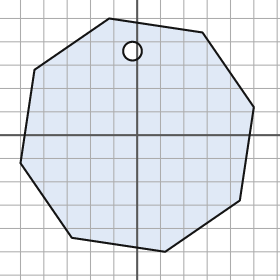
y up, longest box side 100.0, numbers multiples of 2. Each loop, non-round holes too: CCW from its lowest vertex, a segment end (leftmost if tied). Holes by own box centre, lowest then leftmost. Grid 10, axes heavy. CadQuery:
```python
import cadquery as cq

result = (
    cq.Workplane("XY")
    .moveTo(12.0, -50.0)
    .lineTo(44.0, -28.0)
    .lineTo(50.0, 12.0)
    .lineTo(28.0, 44.0)
    .lineTo(-12.0, 50.0)
    .lineTo(-44.0, 28.0)
    .lineTo(-50.0, -12.0)
    .lineTo(-28.0, -44.0)
    .close()
    .moveTo(-2.0, 36.0)
    .circle(4.0)
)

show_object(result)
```